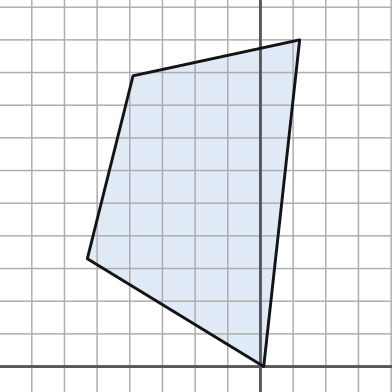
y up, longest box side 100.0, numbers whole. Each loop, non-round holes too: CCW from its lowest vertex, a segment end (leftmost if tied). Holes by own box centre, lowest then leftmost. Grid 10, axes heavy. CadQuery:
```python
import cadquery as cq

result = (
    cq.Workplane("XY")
    .moveTo(1.0, 0.0)
    .lineTo(12.0, 100.0)
    .lineTo(-39.0, 89.0)
    .lineTo(-53.0, 33.0)
    .close()
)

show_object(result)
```